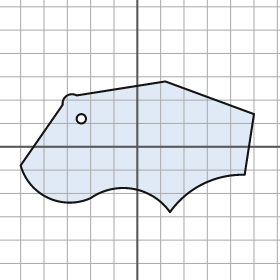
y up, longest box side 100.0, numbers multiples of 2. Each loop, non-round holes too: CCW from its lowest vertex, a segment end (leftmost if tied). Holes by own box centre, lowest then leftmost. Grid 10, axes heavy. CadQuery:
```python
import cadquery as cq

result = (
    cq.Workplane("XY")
    .moveTo(14.0, -28.0)
    .threePointArc((28.0, -16.0), (46.0, -12.0))
    .lineTo(50.0, 14.0)
    .lineTo(12.0, 28.0)
    .lineTo(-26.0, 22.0)
    .threePointArc((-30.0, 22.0), (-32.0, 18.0))
    .lineTo(-50.0, -8.0)
    .threePointArc((-38.0, -22.0), (-20.0, -22.0))
    .threePointArc((-2.0, -18.0), (14.0, -28.0))
    .close()
    .moveTo(-24.0, 12.0)
    .circle(2.0)
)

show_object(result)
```